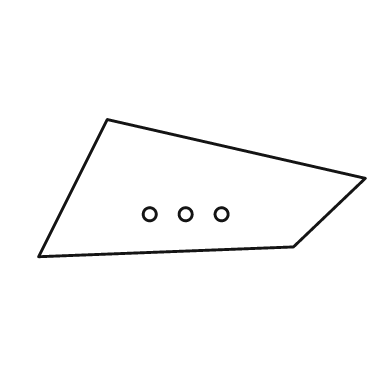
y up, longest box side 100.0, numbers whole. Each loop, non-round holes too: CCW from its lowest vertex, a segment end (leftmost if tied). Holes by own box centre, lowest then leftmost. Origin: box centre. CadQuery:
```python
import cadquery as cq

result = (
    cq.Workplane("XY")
    .moveTo(-50.0, -21.0)
    .lineTo(28.0, -18.0)
    .lineTo(50.0, 3.0)
    .lineTo(-29.0, 21.0)
    .close()
    .moveTo(-16.0, -8.0)
    .circle(2.0)
    .moveTo(-5.0, -8.0)
    .circle(2.0)
    .moveTo(6.0, -8.0)
    .circle(2.0)
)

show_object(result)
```